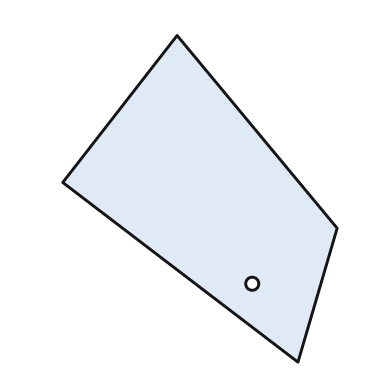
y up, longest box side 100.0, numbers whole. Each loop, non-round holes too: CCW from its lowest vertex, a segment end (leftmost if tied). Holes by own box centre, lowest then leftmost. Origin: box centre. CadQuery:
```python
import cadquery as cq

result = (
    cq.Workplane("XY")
    .moveTo(30.0, -50.0)
    .lineTo(42.0, -9.0)
    .lineTo(-7.0, 50.0)
    .lineTo(-42.0, 5.0)
    .close()
    .moveTo(16.0, -26.0)
    .circle(2.0)
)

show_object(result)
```